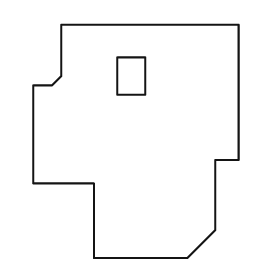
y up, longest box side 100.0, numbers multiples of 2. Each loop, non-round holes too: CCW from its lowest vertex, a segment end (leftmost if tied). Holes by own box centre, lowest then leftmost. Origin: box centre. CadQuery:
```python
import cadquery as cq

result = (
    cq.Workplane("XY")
    .moveTo(-18.0, -50.0)
    .lineTo(22.0, -50.0)
    .lineTo(34.0, -38.0)
    .lineTo(34.0, -8.0)
    .lineTo(44.0, -8.0)
    .lineTo(44.0, 50.0)
    .lineTo(-32.0, 50.0)
    .lineTo(-32.0, 28.0)
    .lineTo(-36.0, 24.0)
    .lineTo(-44.0, 24.0)
    .lineTo(-44.0, -18.0)
    .lineTo(-18.0, -18.0)
    .close()
    .moveTo(-8.0, 20.0)
    .lineTo(4.0, 20.0)
    .lineTo(4.0, 36.0)
    .lineTo(-8.0, 36.0)
    .close()
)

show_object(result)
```